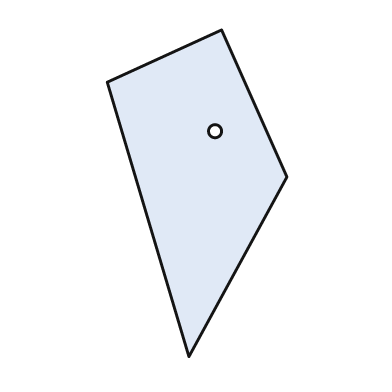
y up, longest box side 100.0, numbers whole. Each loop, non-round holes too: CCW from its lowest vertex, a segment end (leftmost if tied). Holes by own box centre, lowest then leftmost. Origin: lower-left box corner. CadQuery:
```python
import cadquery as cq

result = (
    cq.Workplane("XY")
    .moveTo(25.0, 0.0)
    .lineTo(55.0, 55.0)
    .lineTo(35.0, 100.0)
    .lineTo(0.0, 84.0)
    .close()
    .moveTo(33.0, 69.0)
    .circle(2.0)
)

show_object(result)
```